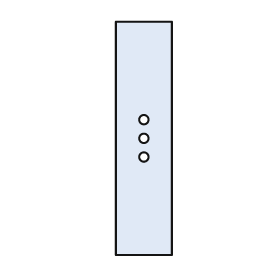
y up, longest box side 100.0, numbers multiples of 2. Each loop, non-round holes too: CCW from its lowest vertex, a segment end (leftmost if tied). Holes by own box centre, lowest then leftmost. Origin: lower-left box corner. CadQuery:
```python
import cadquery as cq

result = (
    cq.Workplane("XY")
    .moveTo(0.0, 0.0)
    .lineTo(24.0, 0.0)
    .lineTo(24.0, 100.0)
    .lineTo(0.0, 100.0)
    .close()
    .moveTo(12.0, 42.0)
    .circle(2.0)
    .moveTo(12.0, 50.0)
    .circle(2.0)
    .moveTo(12.0, 58.0)
    .circle(2.0)
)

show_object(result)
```